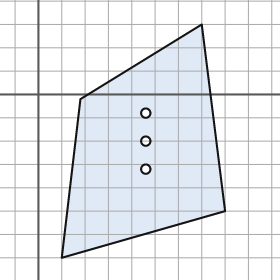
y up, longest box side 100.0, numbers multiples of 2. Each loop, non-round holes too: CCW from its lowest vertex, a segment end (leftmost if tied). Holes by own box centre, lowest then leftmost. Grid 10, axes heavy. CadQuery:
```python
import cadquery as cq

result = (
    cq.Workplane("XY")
    .moveTo(10.0, -70.0)
    .lineTo(80.0, -50.0)
    .lineTo(70.0, 30.0)
    .lineTo(18.0, -2.0)
    .close()
    .moveTo(46.0, -32.0)
    .circle(2.0)
    .moveTo(46.0, -20.0)
    .circle(2.0)
    .moveTo(46.0, -8.0)
    .circle(2.0)
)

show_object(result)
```